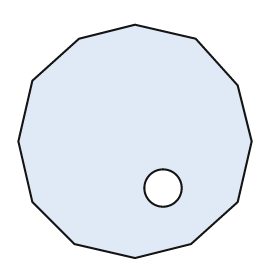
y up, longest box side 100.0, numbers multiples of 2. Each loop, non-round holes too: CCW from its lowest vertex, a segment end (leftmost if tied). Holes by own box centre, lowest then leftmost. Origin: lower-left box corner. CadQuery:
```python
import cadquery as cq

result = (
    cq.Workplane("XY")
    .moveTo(50.0, 0.0)
    .lineTo(74.0, 6.0)
    .lineTo(94.0, 24.0)
    .lineTo(100.0, 50.0)
    .lineTo(94.0, 74.0)
    .lineTo(76.0, 94.0)
    .lineTo(50.0, 100.0)
    .lineTo(26.0, 94.0)
    .lineTo(6.0, 76.0)
    .lineTo(0.0, 50.0)
    .lineTo(6.0, 24.0)
    .lineTo(24.0, 6.0)
    .close()
    .moveTo(62.0, 30.0)
    .circle(8.0)
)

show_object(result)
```